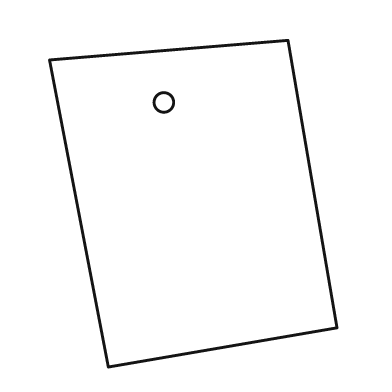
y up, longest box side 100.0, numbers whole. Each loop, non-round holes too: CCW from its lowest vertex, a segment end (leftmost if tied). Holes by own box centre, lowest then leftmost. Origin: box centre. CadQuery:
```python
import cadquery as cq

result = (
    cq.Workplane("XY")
    .moveTo(-26.0, -50.0)
    .lineTo(44.0, -38.0)
    .lineTo(29.0, 50.0)
    .lineTo(-44.0, 44.0)
    .close()
    .moveTo(-9.0, 31.0)
    .circle(3.0)
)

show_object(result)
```